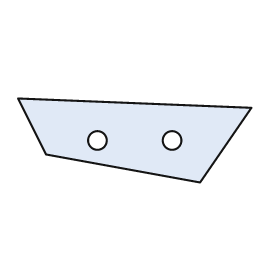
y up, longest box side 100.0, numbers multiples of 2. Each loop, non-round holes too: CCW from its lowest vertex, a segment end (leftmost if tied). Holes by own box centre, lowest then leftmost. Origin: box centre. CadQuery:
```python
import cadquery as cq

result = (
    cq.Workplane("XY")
    .moveTo(28.0, -18.0)
    .lineTo(50.0, 14.0)
    .lineTo(-50.0, 18.0)
    .lineTo(-38.0, -6.0)
    .close()
    .moveTo(-16.0, 0.0)
    .circle(4.0)
    .moveTo(16.0, 0.0)
    .circle(4.0)
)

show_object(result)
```